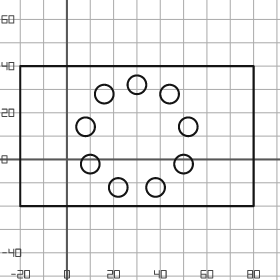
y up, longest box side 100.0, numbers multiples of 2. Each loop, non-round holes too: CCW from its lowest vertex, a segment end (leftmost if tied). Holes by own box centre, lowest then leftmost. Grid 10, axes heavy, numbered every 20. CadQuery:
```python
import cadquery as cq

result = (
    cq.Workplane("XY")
    .moveTo(-20.0, -20.0)
    .lineTo(80.0, -20.0)
    .lineTo(80.0, 40.0)
    .lineTo(-20.0, 40.0)
    .close()
    .moveTo(22.0, -12.0)
    .circle(4.0)
    .moveTo(38.0, -12.0)
    .circle(4.0)
    .moveTo(10.0, -2.0)
    .circle(4.0)
    .moveTo(50.0, -2.0)
    .circle(4.0)
    .moveTo(8.0, 14.0)
    .circle(4.0)
    .moveTo(52.0, 14.0)
    .circle(4.0)
    .moveTo(16.0, 28.0)
    .circle(4.0)
    .moveTo(44.0, 28.0)
    .circle(4.0)
    .moveTo(30.0, 32.0)
    .circle(4.0)
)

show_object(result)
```